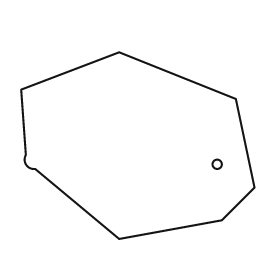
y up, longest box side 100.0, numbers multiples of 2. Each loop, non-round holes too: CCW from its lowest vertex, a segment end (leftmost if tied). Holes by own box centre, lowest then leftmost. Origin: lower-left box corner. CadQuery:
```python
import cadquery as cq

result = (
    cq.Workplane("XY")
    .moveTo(42.0, 0.0)
    .lineTo(86.0, 8.0)
    .lineTo(100.0, 22.0)
    .lineTo(92.0, 60.0)
    .lineTo(42.0, 80.0)
    .lineTo(0.0, 64.0)
    .lineTo(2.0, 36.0)
    .threePointArc((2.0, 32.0), (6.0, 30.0))
    .close()
    .moveTo(84.0, 32.0)
    .circle(2.0)
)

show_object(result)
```